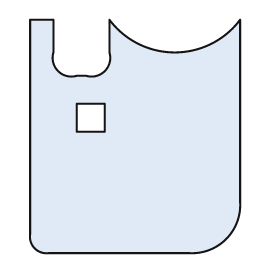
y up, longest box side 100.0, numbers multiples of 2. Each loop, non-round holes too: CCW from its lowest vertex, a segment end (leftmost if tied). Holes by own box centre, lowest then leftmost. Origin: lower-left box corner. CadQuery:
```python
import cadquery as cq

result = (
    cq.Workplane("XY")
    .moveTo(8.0, 0.0)
    .lineTo(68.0, 0.0)
    .threePointArc((84.0, 6.0), (90.0, 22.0))
    .lineTo(90.0, 100.0)
    .threePointArc((62.0, 86.0), (34.0, 100.0))
    .lineTo(34.0, 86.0)
    .threePointArc((32.0, 78.0), (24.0, 76.0))
    .lineTo(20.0, 76.0)
    .threePointArc((12.0, 78.0), (10.0, 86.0))
    .lineTo(10.0, 100.0)
    .lineTo(0.0, 100.0)
    .lineTo(0.0, 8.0)
    .threePointArc((2.0, 2.0), (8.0, 0.0))
    .close()
    .moveTo(20.0, 52.0)
    .lineTo(32.0, 52.0)
    .lineTo(32.0, 64.0)
    .lineTo(20.0, 64.0)
    .close()
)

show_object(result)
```